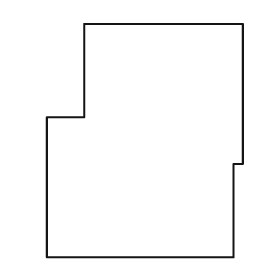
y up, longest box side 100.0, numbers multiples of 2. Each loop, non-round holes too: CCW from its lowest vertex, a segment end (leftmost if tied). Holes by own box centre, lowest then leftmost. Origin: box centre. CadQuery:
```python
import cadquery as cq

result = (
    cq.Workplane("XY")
    .moveTo(-42.0, -50.0)
    .lineTo(38.0, -50.0)
    .lineTo(38.0, -10.0)
    .lineTo(42.0, -10.0)
    .lineTo(42.0, 50.0)
    .lineTo(-26.0, 50.0)
    .lineTo(-26.0, 10.0)
    .lineTo(-42.0, 10.0)
    .close()
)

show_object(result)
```